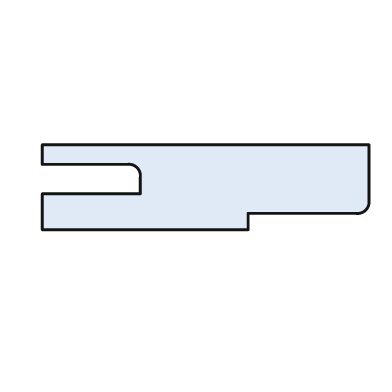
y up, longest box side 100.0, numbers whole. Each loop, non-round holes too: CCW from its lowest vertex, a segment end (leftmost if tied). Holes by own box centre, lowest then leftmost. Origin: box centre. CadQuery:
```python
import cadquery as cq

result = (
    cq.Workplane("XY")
    .moveTo(-50.0, -13.0)
    .lineTo(13.0, -13.0)
    .lineTo(13.0, -8.0)
    .lineTo(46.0, -8.0)
    .threePointArc((49.0, -7.0), (50.0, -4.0))
    .lineTo(50.0, 13.0)
    .lineTo(-50.0, 13.0)
    .lineTo(-50.0, 7.0)
    .lineTo(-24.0, 7.0)
    .threePointArc((-21.0, 6.0), (-20.0, 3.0))
    .lineTo(-20.0, -2.0)
    .lineTo(-50.0, -2.0)
    .close()
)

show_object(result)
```